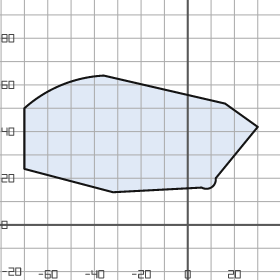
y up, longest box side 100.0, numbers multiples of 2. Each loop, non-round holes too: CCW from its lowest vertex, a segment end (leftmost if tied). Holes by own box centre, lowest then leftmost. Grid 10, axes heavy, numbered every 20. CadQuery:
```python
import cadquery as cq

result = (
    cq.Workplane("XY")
    .moveTo(-32.0, 14.0)
    .lineTo(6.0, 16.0)
    .threePointArc((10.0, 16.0), (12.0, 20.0))
    .lineTo(30.0, 42.0)
    .lineTo(16.0, 52.0)
    .lineTo(-36.0, 64.0)
    .threePointArc((-54.0, 60.0), (-70.0, 50.0))
    .lineTo(-70.0, 24.0)
    .close()
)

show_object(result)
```